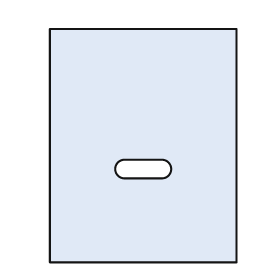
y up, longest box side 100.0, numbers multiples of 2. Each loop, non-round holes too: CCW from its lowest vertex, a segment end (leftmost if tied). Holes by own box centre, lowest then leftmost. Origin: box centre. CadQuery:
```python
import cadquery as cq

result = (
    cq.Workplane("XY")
    .moveTo(-40.0, -50.0)
    .lineTo(40.0, -50.0)
    .lineTo(40.0, 50.0)
    .lineTo(-40.0, 50.0)
    .close()
    .moveTo(-8.0, -14.0)
    .lineTo(8.0, -14.0)
    .threePointArc((12.0, -10.0), (8.0, -6.0))
    .lineTo(-8.0, -6.0)
    .threePointArc((-12.0, -10.0), (-8.0, -14.0))
    .close()
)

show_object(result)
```